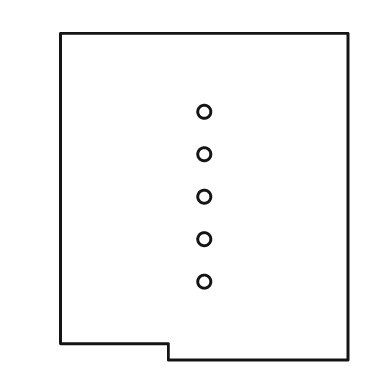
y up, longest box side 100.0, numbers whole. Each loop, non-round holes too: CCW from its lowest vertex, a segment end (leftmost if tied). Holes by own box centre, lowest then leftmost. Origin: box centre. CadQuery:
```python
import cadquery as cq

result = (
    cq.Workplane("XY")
    .moveTo(-11.0, -50.0)
    .lineTo(44.0, -50.0)
    .lineTo(44.0, 50.0)
    .lineTo(-44.0, 50.0)
    .lineTo(-44.0, -45.0)
    .lineTo(-11.0, -45.0)
    .close()
    .moveTo(0.0, -26.0)
    .circle(2.0)
    .moveTo(0.0, -13.0)
    .circle(2.0)
    .moveTo(0.0, 0.0)
    .circle(2.0)
    .moveTo(0.0, 13.0)
    .circle(2.0)
    .moveTo(0.0, 26.0)
    .circle(2.0)
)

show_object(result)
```